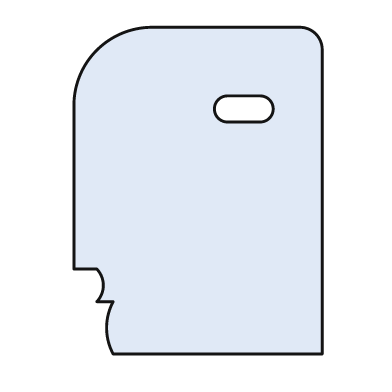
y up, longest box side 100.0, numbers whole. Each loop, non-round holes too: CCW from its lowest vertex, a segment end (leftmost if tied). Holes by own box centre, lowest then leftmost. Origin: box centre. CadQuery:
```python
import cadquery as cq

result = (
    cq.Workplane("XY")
    .moveTo(-26.0, -50.0)
    .lineTo(38.0, -50.0)
    .lineTo(38.0, 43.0)
    .threePointArc((36.0, 48.0), (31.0, 50.0))
    .lineTo(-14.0, 50.0)
    .threePointArc((-31.0, 43.0), (-38.0, 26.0))
    .lineTo(-38.0, -24.0)
    .lineTo(-31.0, -24.0)
    .threePointArc((-29.0, -29.0), (-31.0, -34.0))
    .lineTo(-26.0, -34.0)
    .threePointArc((-28.0, -42.0), (-26.0, -50.0))
    .close()
    .moveTo(9.0, 21.0)
    .lineTo(19.0, 21.0)
    .threePointArc((23.0, 25.0), (19.0, 29.0))
    .lineTo(9.0, 29.0)
    .threePointArc((5.0, 25.0), (9.0, 21.0))
    .close()
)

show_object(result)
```